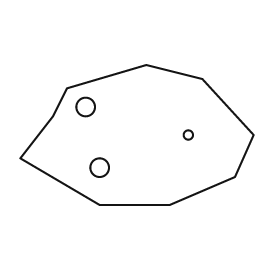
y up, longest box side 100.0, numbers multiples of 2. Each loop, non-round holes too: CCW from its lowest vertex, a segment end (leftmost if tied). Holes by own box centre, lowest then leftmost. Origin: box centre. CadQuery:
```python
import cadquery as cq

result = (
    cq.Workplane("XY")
    .moveTo(-16.0, -30.0)
    .lineTo(14.0, -30.0)
    .lineTo(42.0, -18.0)
    .lineTo(50.0, 0.0)
    .lineTo(28.0, 24.0)
    .lineTo(4.0, 30.0)
    .lineTo(-30.0, 20.0)
    .lineTo(-36.0, 8.0)
    .lineTo(-50.0, -10.0)
    .close()
    .moveTo(-16.0, -14.0)
    .circle(4.0)
    .moveTo(22.0, 0.0)
    .circle(2.0)
    .moveTo(-22.0, 12.0)
    .circle(4.0)
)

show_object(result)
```